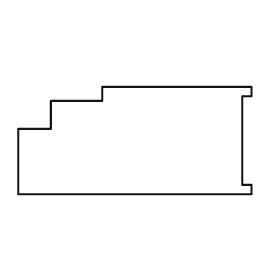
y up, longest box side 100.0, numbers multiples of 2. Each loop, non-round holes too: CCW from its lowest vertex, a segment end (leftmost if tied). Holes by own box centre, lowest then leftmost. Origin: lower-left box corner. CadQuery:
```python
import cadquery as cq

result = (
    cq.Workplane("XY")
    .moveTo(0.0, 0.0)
    .lineTo(100.0, 0.0)
    .lineTo(100.0, 4.0)
    .lineTo(96.0, 4.0)
    .lineTo(96.0, 42.0)
    .lineTo(100.0, 42.0)
    .lineTo(100.0, 46.0)
    .lineTo(36.0, 46.0)
    .lineTo(36.0, 40.0)
    .lineTo(14.0, 40.0)
    .lineTo(14.0, 28.0)
    .lineTo(0.0, 28.0)
    .close()
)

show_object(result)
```